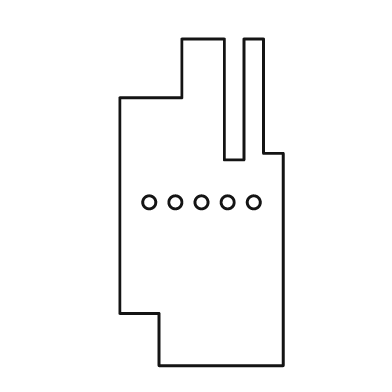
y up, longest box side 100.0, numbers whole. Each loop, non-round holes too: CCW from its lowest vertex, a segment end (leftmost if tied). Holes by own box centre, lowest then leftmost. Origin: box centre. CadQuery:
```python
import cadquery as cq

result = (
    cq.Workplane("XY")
    .moveTo(-13.0, -50.0)
    .lineTo(25.0, -50.0)
    .lineTo(25.0, 15.0)
    .lineTo(19.0, 15.0)
    .lineTo(19.0, 50.0)
    .lineTo(13.0, 50.0)
    .lineTo(13.0, 13.0)
    .lineTo(7.0, 13.0)
    .lineTo(7.0, 50.0)
    .lineTo(-6.0, 50.0)
    .lineTo(-6.0, 32.0)
    .lineTo(-25.0, 32.0)
    .lineTo(-25.0, -34.0)
    .lineTo(-13.0, -34.0)
    .close()
    .moveTo(-16.0, 0.0)
    .circle(2.0)
    .moveTo(-8.0, 0.0)
    .circle(2.0)
    .moveTo(0.0, 0.0)
    .circle(2.0)
    .moveTo(8.0, 0.0)
    .circle(2.0)
    .moveTo(16.0, 0.0)
    .circle(2.0)
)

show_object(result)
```